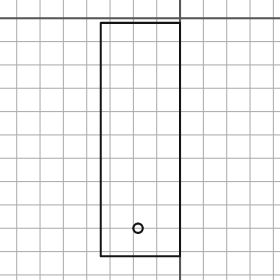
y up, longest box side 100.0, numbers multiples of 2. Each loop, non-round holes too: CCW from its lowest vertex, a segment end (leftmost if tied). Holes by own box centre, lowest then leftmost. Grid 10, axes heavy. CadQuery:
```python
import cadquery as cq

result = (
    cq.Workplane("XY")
    .moveTo(-34.0, -102.0)
    .lineTo(0.0, -102.0)
    .lineTo(0.0, -2.0)
    .lineTo(-34.0, -2.0)
    .close()
    .moveTo(-18.0, -90.0)
    .circle(2.0)
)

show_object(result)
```